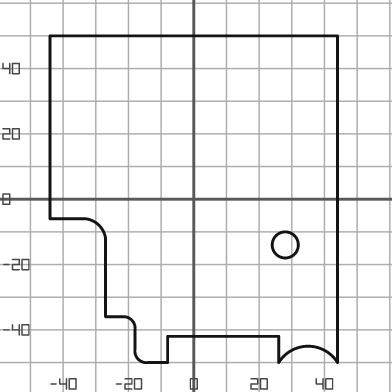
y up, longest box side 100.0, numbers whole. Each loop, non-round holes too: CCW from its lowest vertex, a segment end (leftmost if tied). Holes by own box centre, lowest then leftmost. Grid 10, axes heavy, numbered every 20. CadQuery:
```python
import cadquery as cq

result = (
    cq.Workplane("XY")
    .moveTo(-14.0, -50.0)
    .lineTo(-8.0, -50.0)
    .lineTo(-8.0, -42.0)
    .lineTo(26.0, -42.0)
    .lineTo(26.0, -50.0)
    .threePointArc((35.0, -45.0), (44.0, -50.0))
    .lineTo(44.0, 50.0)
    .lineTo(-44.0, 50.0)
    .lineTo(-44.0, -6.0)
    .lineTo(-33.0, -6.0)
    .threePointArc((-29.0, -8.0), (-27.0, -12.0))
    .lineTo(-27.0, -36.0)
    .lineTo(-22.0, -36.0)
    .threePointArc((-19.0, -37.0), (-18.0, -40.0))
    .lineTo(-18.0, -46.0)
    .threePointArc((-17.0, -49.0), (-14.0, -50.0))
    .close()
    .moveTo(28.0, -14.0)
    .circle(4.0)
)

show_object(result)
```